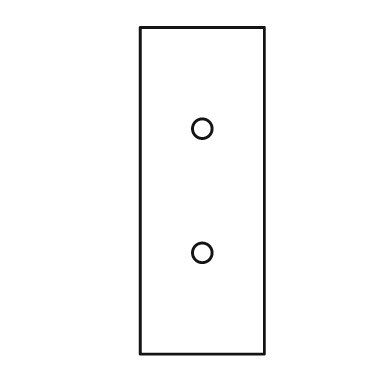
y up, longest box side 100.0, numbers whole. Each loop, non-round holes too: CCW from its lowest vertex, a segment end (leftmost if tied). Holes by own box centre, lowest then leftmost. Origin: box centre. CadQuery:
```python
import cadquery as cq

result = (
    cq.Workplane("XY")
    .moveTo(-19.0, -50.0)
    .lineTo(19.0, -50.0)
    .lineTo(19.0, 50.0)
    .lineTo(-19.0, 50.0)
    .close()
    .moveTo(0.0, -19.0)
    .circle(3.0)
    .moveTo(0.0, 19.0)
    .circle(3.0)
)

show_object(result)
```